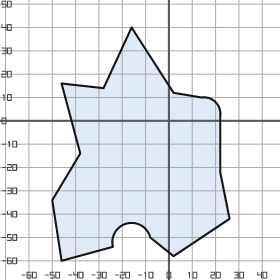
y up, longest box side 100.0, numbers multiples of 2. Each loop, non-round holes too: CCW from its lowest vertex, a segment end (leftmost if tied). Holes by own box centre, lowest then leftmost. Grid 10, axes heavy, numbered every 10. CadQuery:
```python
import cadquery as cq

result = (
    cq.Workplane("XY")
    .moveTo(-46.0, -60.0)
    .lineTo(-24.0, -54.0)
    .threePointArc((-18.0, -44.0), (-8.0, -50.0))
    .lineTo(2.0, -58.0)
    .lineTo(26.0, -42.0)
    .lineTo(22.0, -22.0)
    .lineTo(22.0, 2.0)
    .threePointArc((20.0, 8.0), (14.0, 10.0))
    .lineTo(2.0, 12.0)
    .lineTo(-16.0, 40.0)
    .lineTo(-28.0, 14.0)
    .lineTo(-46.0, 16.0)
    .lineTo(-38.0, -14.0)
    .lineTo(-50.0, -34.0)
    .close()
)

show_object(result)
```